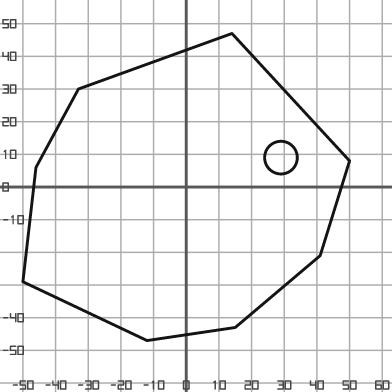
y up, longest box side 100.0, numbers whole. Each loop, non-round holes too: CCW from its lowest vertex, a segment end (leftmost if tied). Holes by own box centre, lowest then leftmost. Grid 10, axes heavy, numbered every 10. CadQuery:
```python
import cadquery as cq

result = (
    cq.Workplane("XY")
    .moveTo(-12.0, -47.0)
    .lineTo(15.0, -43.0)
    .lineTo(41.0, -21.0)
    .lineTo(50.0, 8.0)
    .lineTo(14.0, 47.0)
    .lineTo(-33.0, 30.0)
    .lineTo(-46.0, 6.0)
    .lineTo(-50.0, -29.0)
    .close()
    .moveTo(29.0, 9.0)
    .circle(5.0)
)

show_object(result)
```